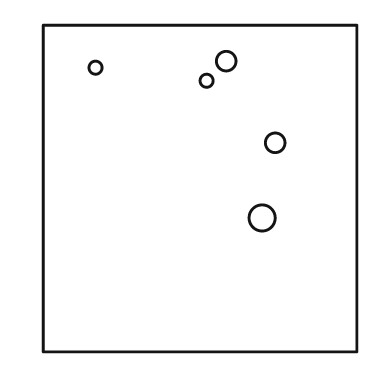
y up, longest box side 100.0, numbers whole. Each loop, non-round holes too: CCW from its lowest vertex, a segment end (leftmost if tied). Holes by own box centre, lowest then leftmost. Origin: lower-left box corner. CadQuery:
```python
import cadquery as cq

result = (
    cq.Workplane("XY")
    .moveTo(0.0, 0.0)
    .lineTo(96.0, 0.0)
    .lineTo(96.0, 100.0)
    .lineTo(0.0, 100.0)
    .close()
    .moveTo(67.0, 41.0)
    .circle(4.0)
    .moveTo(71.0, 64.0)
    .circle(3.0)
    .moveTo(50.0, 83.0)
    .circle(2.0)
    .moveTo(16.0, 87.0)
    .circle(2.0)
    .moveTo(56.0, 89.0)
    .circle(3.0)
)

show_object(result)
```